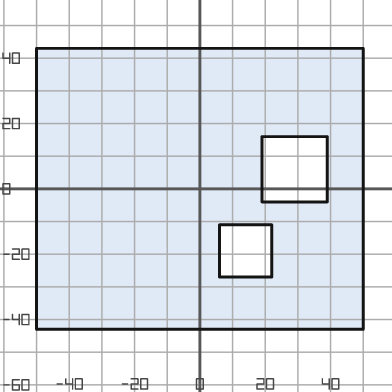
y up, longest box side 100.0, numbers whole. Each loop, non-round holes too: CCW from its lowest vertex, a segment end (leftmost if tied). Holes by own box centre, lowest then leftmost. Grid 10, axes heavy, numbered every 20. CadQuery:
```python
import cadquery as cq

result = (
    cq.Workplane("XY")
    .moveTo(-50.0, -43.0)
    .lineTo(50.0, -43.0)
    .lineTo(50.0, 43.0)
    .lineTo(-50.0, 43.0)
    .close()
    .moveTo(6.0, -27.0)
    .lineTo(22.0, -27.0)
    .lineTo(22.0, -11.0)
    .lineTo(6.0, -11.0)
    .close()
    .moveTo(19.0, -4.0)
    .lineTo(39.0, -4.0)
    .lineTo(39.0, 16.0)
    .lineTo(19.0, 16.0)
    .close()
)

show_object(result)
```